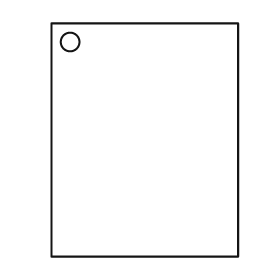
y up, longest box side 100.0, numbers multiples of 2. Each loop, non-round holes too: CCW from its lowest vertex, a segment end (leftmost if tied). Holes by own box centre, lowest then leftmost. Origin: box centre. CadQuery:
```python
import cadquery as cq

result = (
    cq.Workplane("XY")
    .moveTo(-40.0, -50.0)
    .lineTo(40.0, -50.0)
    .lineTo(40.0, 50.0)
    .lineTo(-40.0, 50.0)
    .close()
    .moveTo(-32.0, 42.0)
    .circle(4.0)
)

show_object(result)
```